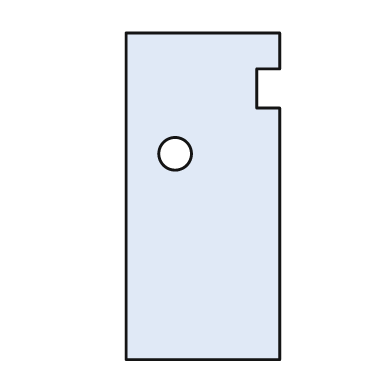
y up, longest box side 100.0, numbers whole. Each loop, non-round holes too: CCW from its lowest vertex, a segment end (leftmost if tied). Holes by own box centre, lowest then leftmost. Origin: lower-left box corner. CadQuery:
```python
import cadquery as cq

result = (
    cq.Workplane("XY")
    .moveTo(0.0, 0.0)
    .lineTo(47.0, 0.0)
    .lineTo(47.0, 77.0)
    .lineTo(40.0, 77.0)
    .lineTo(40.0, 89.0)
    .lineTo(47.0, 89.0)
    .lineTo(47.0, 100.0)
    .lineTo(0.0, 100.0)
    .close()
    .moveTo(15.0, 63.0)
    .circle(5.0)
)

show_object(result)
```